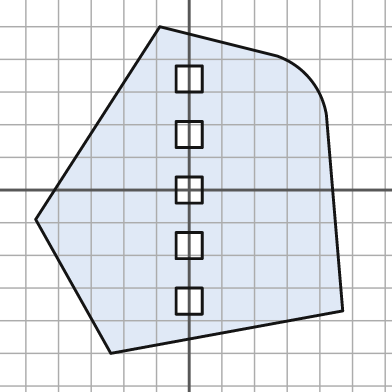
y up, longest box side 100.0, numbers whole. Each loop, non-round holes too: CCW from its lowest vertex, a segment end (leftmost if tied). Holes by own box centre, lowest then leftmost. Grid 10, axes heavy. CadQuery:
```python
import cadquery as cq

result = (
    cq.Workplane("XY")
    .moveTo(-24.0, -50.0)
    .lineTo(47.0, -37.0)
    .lineTo(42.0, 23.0)
    .threePointArc((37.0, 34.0), (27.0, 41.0))
    .lineTo(-9.0, 50.0)
    .lineTo(-47.0, -9.0)
    .close()
    .moveTo(-4.0, -38.0)
    .lineTo(4.0, -38.0)
    .lineTo(4.0, -30.0)
    .lineTo(-4.0, -30.0)
    .close()
    .moveTo(-4.0, -21.0)
    .lineTo(4.0, -21.0)
    .lineTo(4.0, -13.0)
    .lineTo(-4.0, -13.0)
    .close()
    .moveTo(-4.0, -4.0)
    .lineTo(4.0, -4.0)
    .lineTo(4.0, 4.0)
    .lineTo(-4.0, 4.0)
    .close()
    .moveTo(-4.0, 13.0)
    .lineTo(4.0, 13.0)
    .lineTo(4.0, 21.0)
    .lineTo(-4.0, 21.0)
    .close()
    .moveTo(-4.0, 30.0)
    .lineTo(4.0, 30.0)
    .lineTo(4.0, 38.0)
    .lineTo(-4.0, 38.0)
    .close()
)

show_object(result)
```